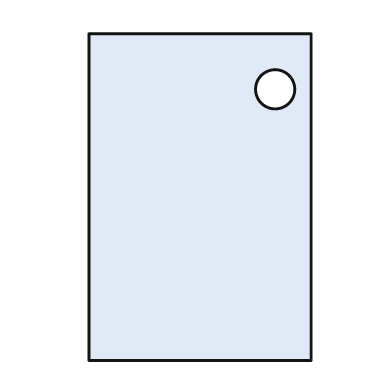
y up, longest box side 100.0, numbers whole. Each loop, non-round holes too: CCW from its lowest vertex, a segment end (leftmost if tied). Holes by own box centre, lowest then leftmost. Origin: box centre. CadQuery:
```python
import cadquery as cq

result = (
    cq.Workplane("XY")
    .moveTo(-34.0, -50.0)
    .lineTo(34.0, -50.0)
    .lineTo(34.0, 50.0)
    .lineTo(-34.0, 50.0)
    .close()
    .moveTo(23.0, 33.0)
    .circle(6.0)
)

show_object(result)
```